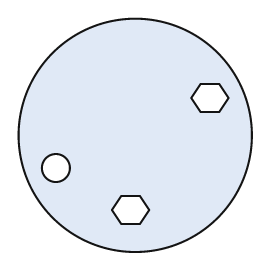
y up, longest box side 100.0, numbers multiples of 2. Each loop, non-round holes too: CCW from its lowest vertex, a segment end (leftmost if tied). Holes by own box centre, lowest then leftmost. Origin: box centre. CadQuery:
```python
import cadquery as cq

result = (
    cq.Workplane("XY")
    .moveTo(0.0, 0.0)
    .circle(50.0)
    .moveTo(-6.0, -38.0)
    .lineTo(2.0, -38.0)
    .lineTo(6.0, -32.0)
    .lineTo(2.0, -26.0)
    .lineTo(-6.0, -26.0)
    .lineTo(-10.0, -32.0)
    .close()
    .moveTo(-34.0, -14.0)
    .circle(6.0)
    .moveTo(28.0, 10.0)
    .lineTo(36.0, 10.0)
    .lineTo(40.0, 16.0)
    .lineTo(36.0, 22.0)
    .lineTo(28.0, 22.0)
    .lineTo(24.0, 16.0)
    .close()
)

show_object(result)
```